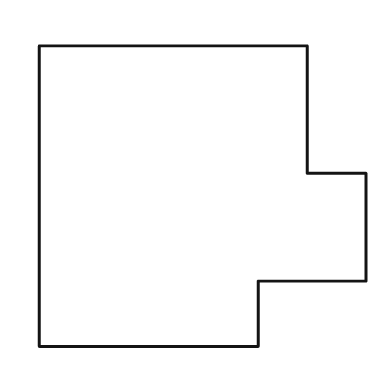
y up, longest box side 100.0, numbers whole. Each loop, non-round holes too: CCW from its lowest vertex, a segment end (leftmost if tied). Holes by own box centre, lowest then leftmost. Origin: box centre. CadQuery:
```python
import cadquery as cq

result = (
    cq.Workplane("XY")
    .moveTo(-50.0, -46.0)
    .lineTo(17.0, -46.0)
    .lineTo(17.0, -26.0)
    .lineTo(50.0, -26.0)
    .lineTo(50.0, 7.0)
    .lineTo(32.0, 7.0)
    .lineTo(32.0, 46.0)
    .lineTo(-50.0, 46.0)
    .close()
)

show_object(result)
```